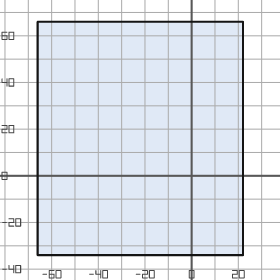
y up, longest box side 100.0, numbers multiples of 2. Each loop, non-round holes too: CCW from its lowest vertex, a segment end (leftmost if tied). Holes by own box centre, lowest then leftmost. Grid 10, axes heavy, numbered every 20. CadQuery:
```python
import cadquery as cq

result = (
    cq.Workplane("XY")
    .moveTo(-66.0, -34.0)
    .lineTo(22.0, -34.0)
    .lineTo(22.0, 66.0)
    .lineTo(-66.0, 66.0)
    .close()
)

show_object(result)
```